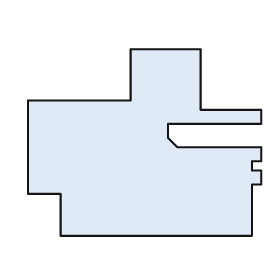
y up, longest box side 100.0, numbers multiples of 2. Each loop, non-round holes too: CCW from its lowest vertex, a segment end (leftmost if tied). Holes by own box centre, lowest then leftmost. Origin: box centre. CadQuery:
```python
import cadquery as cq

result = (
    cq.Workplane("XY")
    .moveTo(-36.0, -40.0)
    .lineTo(46.0, -40.0)
    .lineTo(46.0, -18.0)
    .lineTo(50.0, -18.0)
    .lineTo(50.0, -12.0)
    .lineTo(46.0, -12.0)
    .lineTo(46.0, -8.0)
    .lineTo(50.0, -8.0)
    .lineTo(50.0, -2.0)
    .lineTo(14.0, -2.0)
    .lineTo(10.0, 2.0)
    .lineTo(10.0, 8.0)
    .lineTo(50.0, 8.0)
    .lineTo(50.0, 14.0)
    .lineTo(24.0, 14.0)
    .lineTo(24.0, 40.0)
    .lineTo(-6.0, 40.0)
    .lineTo(-6.0, 18.0)
    .lineTo(-50.0, 18.0)
    .lineTo(-50.0, -22.0)
    .lineTo(-36.0, -22.0)
    .close()
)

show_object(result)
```